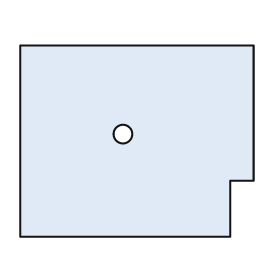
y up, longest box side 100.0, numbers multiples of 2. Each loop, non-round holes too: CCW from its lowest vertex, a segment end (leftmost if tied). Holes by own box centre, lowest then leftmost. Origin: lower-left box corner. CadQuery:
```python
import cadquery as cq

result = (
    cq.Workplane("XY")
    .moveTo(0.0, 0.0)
    .lineTo(90.0, 0.0)
    .lineTo(90.0, 24.0)
    .lineTo(100.0, 24.0)
    .lineTo(100.0, 82.0)
    .lineTo(0.0, 82.0)
    .close()
    .moveTo(44.0, 44.0)
    .circle(4.0)
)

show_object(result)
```